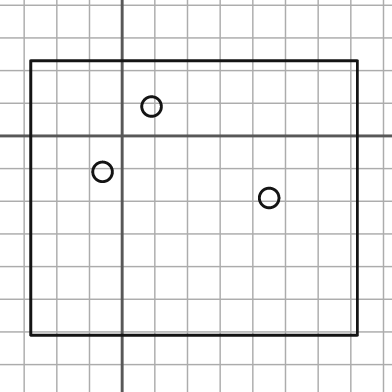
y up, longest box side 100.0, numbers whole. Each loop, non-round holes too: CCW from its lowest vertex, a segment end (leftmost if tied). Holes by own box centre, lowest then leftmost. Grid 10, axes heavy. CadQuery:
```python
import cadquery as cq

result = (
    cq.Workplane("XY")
    .moveTo(-28.0, -61.0)
    .lineTo(72.0, -61.0)
    .lineTo(72.0, 23.0)
    .lineTo(-28.0, 23.0)
    .close()
    .moveTo(45.0, -19.0)
    .circle(3.0)
    .moveTo(-6.0, -11.0)
    .circle(3.0)
    .moveTo(9.0, 9.0)
    .circle(3.0)
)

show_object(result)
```